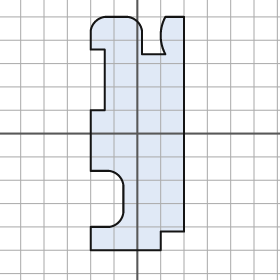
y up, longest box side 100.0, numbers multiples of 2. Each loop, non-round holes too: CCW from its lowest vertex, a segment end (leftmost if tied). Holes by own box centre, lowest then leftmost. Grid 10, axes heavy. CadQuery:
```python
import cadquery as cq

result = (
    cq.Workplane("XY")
    .moveTo(-20.0, -50.0)
    .lineTo(10.0, -50.0)
    .lineTo(10.0, -42.0)
    .lineTo(20.0, -42.0)
    .lineTo(20.0, 50.0)
    .lineTo(12.0, 50.0)
    .threePointArc((10.0, 42.0), (12.0, 34.0))
    .lineTo(2.0, 34.0)
    .lineTo(2.0, 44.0)
    .threePointArc((0.0, 48.0), (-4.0, 50.0))
    .lineTo(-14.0, 50.0)
    .threePointArc((-18.0, 48.0), (-20.0, 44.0))
    .lineTo(-20.0, 36.0)
    .lineTo(-14.0, 36.0)
    .lineTo(-14.0, 10.0)
    .lineTo(-20.0, 10.0)
    .lineTo(-20.0, -16.0)
    .lineTo(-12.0, -16.0)
    .threePointArc((-8.0, -18.0), (-6.0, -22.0))
    .lineTo(-6.0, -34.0)
    .threePointArc((-8.0, -38.0), (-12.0, -40.0))
    .lineTo(-20.0, -40.0)
    .close()
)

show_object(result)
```